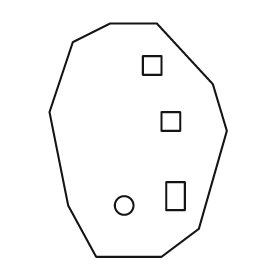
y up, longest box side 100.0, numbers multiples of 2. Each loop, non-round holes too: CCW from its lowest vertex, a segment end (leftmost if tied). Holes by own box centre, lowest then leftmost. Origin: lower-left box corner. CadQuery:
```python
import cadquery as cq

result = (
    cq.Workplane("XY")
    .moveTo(20.0, 0.0)
    .lineTo(48.0, 0.0)
    .lineTo(64.0, 12.0)
    .lineTo(76.0, 54.0)
    .lineTo(70.0, 74.0)
    .lineTo(46.0, 100.0)
    .lineTo(26.0, 100.0)
    .lineTo(10.0, 92.0)
    .lineTo(0.0, 62.0)
    .lineTo(8.0, 22.0)
    .close()
    .moveTo(32.0, 22.0)
    .circle(4.0)
    .moveTo(50.0, 20.0)
    .lineTo(58.0, 20.0)
    .lineTo(58.0, 32.0)
    .lineTo(50.0, 32.0)
    .close()
    .moveTo(48.0, 54.0)
    .lineTo(56.0, 54.0)
    .lineTo(56.0, 62.0)
    .lineTo(48.0, 62.0)
    .close()
    .moveTo(40.0, 78.0)
    .lineTo(48.0, 78.0)
    .lineTo(48.0, 86.0)
    .lineTo(40.0, 86.0)
    .close()
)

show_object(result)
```